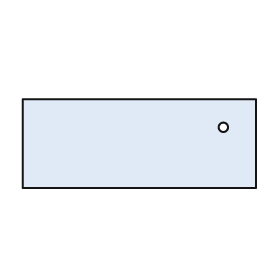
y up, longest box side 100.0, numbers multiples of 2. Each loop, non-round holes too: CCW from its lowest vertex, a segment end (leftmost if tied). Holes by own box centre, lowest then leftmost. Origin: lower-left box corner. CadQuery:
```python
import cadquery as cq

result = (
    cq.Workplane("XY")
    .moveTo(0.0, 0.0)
    .lineTo(100.0, 0.0)
    .lineTo(100.0, 38.0)
    .lineTo(0.0, 38.0)
    .close()
    .moveTo(86.0, 26.0)
    .circle(2.0)
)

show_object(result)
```